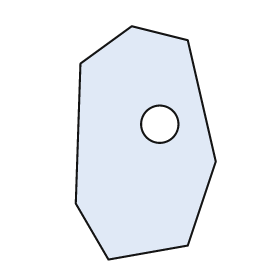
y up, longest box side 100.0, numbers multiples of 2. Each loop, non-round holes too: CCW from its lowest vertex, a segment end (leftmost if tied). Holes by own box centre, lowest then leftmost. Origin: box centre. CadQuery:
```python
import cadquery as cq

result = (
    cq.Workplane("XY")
    .moveTo(-16.0, -50.0)
    .lineTo(18.0, -44.0)
    .lineTo(30.0, -8.0)
    .lineTo(18.0, 44.0)
    .lineTo(-6.0, 50.0)
    .lineTo(-28.0, 34.0)
    .lineTo(-30.0, -26.0)
    .close()
    .moveTo(6.0, 8.0)
    .circle(8.0)
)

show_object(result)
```